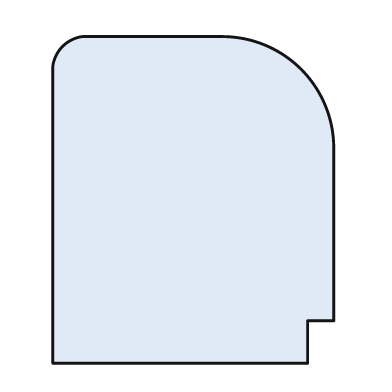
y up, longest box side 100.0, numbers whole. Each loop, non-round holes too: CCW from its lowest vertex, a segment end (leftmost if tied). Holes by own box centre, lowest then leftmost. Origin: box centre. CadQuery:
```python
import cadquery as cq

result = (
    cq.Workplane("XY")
    .moveTo(-43.0, -50.0)
    .lineTo(35.0, -50.0)
    .lineTo(35.0, -37.0)
    .lineTo(43.0, -37.0)
    .lineTo(43.0, 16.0)
    .threePointArc((33.0, 40.0), (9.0, 50.0))
    .lineTo(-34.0, 50.0)
    .threePointArc((-40.0, 47.0), (-43.0, 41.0))
    .close()
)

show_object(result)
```